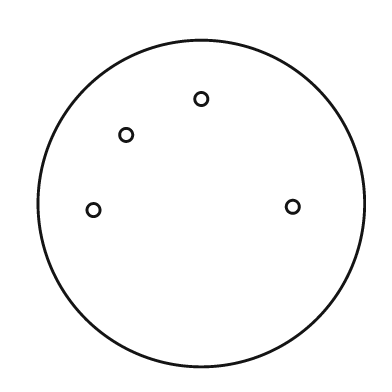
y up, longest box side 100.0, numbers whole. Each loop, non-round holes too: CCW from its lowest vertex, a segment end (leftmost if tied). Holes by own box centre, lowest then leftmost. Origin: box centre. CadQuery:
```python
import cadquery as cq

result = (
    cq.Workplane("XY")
    .moveTo(0.0, 0.0)
    .circle(50.0)
    .moveTo(-33.0, -2.0)
    .circle(2.0)
    .moveTo(28.0, -1.0)
    .circle(2.0)
    .moveTo(-23.0, 21.0)
    .circle(2.0)
    .moveTo(0.0, 32.0)
    .circle(2.0)
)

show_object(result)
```